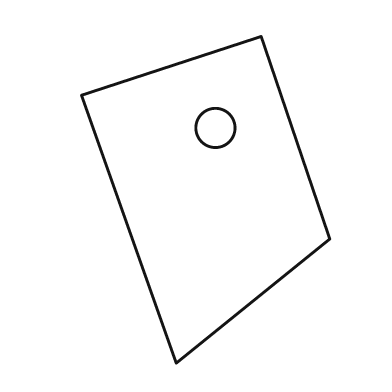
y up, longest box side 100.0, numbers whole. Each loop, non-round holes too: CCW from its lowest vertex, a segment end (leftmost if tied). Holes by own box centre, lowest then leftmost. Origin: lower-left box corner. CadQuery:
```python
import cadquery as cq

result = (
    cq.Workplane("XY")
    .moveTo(29.0, 0.0)
    .lineTo(76.0, 38.0)
    .lineTo(55.0, 100.0)
    .lineTo(0.0, 82.0)
    .close()
    .moveTo(41.0, 72.0)
    .circle(6.0)
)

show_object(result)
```